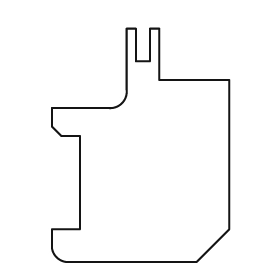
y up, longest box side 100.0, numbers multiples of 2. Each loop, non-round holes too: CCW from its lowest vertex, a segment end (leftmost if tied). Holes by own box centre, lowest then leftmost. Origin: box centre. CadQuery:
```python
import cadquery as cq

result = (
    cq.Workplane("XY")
    .moveTo(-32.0, -50.0)
    .lineTo(24.0, -50.0)
    .lineTo(38.0, -36.0)
    .lineTo(38.0, 28.0)
    .lineTo(8.0, 28.0)
    .lineTo(8.0, 50.0)
    .lineTo(4.0, 50.0)
    .lineTo(4.0, 36.0)
    .lineTo(-2.0, 36.0)
    .lineTo(-2.0, 50.0)
    .lineTo(-6.0, 50.0)
    .lineTo(-6.0, 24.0)
    .threePointArc((-8.0, 18.0), (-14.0, 16.0))
    .lineTo(-38.0, 16.0)
    .lineTo(-38.0, 8.0)
    .lineTo(-34.0, 4.0)
    .lineTo(-26.0, 4.0)
    .lineTo(-26.0, -36.0)
    .lineTo(-38.0, -36.0)
    .lineTo(-38.0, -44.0)
    .threePointArc((-36.0, -48.0), (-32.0, -50.0))
    .close()
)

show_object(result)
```